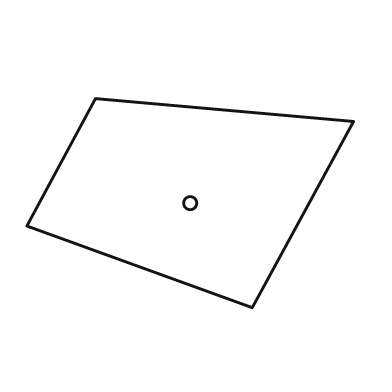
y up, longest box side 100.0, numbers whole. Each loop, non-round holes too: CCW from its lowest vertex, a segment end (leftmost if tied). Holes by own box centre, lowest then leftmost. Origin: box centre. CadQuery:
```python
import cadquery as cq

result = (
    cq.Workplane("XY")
    .moveTo(19.0, -32.0)
    .lineTo(50.0, 25.0)
    .lineTo(-29.0, 32.0)
    .lineTo(-50.0, -7.0)
    .close()
    .moveTo(0.0, 0.0)
    .circle(2.0)
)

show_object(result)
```